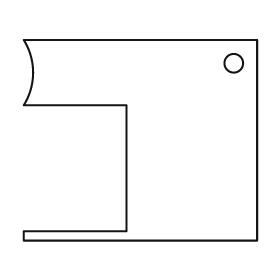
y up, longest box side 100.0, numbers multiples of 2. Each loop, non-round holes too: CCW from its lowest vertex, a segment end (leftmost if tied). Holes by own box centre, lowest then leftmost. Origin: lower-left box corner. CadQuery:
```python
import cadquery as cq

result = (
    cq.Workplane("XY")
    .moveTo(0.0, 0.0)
    .lineTo(100.0, 0.0)
    .lineTo(100.0, 86.0)
    .lineTo(0.0, 86.0)
    .threePointArc((4.0, 72.0), (0.0, 58.0))
    .lineTo(44.0, 58.0)
    .lineTo(44.0, 4.0)
    .lineTo(0.0, 4.0)
    .close()
    .moveTo(90.0, 76.0)
    .circle(4.0)
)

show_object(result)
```